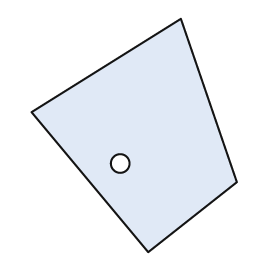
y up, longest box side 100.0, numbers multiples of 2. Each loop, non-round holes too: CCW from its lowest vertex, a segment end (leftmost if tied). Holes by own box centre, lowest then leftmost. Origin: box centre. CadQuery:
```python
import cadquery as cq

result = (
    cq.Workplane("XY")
    .moveTo(6.0, -50.0)
    .lineTo(44.0, -20.0)
    .lineTo(20.0, 50.0)
    .lineTo(-44.0, 10.0)
    .close()
    .moveTo(-6.0, -12.0)
    .circle(4.0)
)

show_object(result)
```